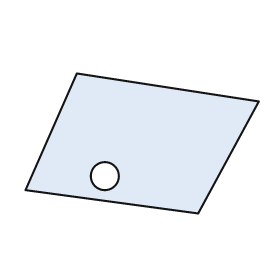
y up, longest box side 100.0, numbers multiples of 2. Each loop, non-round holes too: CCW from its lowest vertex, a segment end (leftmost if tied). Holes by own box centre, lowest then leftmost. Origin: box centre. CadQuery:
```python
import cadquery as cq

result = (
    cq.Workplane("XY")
    .moveTo(24.0, -30.0)
    .lineTo(50.0, 18.0)
    .lineTo(-28.0, 30.0)
    .lineTo(-50.0, -20.0)
    .close()
    .moveTo(-16.0, -14.0)
    .circle(6.0)
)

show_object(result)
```